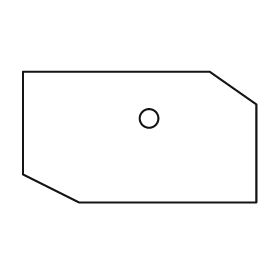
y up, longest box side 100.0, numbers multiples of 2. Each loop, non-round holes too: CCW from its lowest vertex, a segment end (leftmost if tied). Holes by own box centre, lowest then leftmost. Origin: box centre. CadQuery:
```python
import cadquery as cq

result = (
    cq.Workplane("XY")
    .moveTo(-26.0, -28.0)
    .lineTo(50.0, -28.0)
    .lineTo(50.0, 14.0)
    .lineTo(30.0, 28.0)
    .lineTo(-50.0, 28.0)
    .lineTo(-50.0, -16.0)
    .close()
    .moveTo(4.0, 8.0)
    .circle(4.0)
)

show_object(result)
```